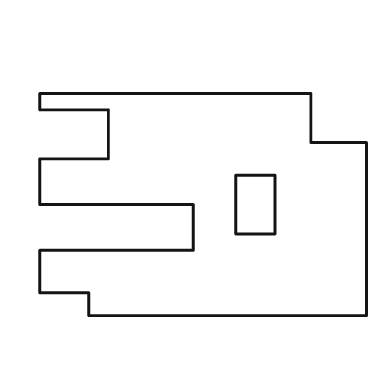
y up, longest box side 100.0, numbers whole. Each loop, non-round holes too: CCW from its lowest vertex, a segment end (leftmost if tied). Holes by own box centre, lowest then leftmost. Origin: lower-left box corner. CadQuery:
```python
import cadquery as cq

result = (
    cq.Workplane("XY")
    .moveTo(15.0, 0.0)
    .lineTo(100.0, 0.0)
    .lineTo(100.0, 53.0)
    .lineTo(83.0, 53.0)
    .lineTo(83.0, 68.0)
    .lineTo(0.0, 68.0)
    .lineTo(0.0, 63.0)
    .lineTo(21.0, 63.0)
    .lineTo(21.0, 48.0)
    .lineTo(0.0, 48.0)
    .lineTo(0.0, 34.0)
    .lineTo(47.0, 34.0)
    .lineTo(47.0, 20.0)
    .lineTo(0.0, 20.0)
    .lineTo(0.0, 7.0)
    .lineTo(15.0, 7.0)
    .close()
    .moveTo(60.0, 25.0)
    .lineTo(72.0, 25.0)
    .lineTo(72.0, 43.0)
    .lineTo(60.0, 43.0)
    .close()
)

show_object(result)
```